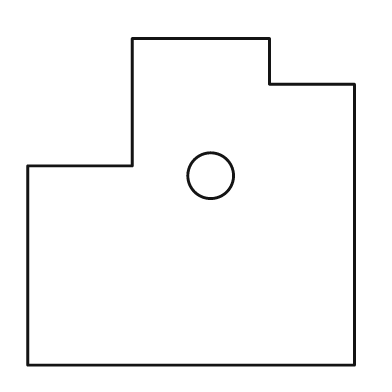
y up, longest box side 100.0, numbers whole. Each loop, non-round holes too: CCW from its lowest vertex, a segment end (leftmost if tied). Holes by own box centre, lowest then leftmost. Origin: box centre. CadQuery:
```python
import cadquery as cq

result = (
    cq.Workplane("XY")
    .moveTo(-50.0, -50.0)
    .lineTo(50.0, -50.0)
    .lineTo(50.0, 36.0)
    .lineTo(24.0, 36.0)
    .lineTo(24.0, 50.0)
    .lineTo(-18.0, 50.0)
    .lineTo(-18.0, 11.0)
    .lineTo(-50.0, 11.0)
    .close()
    .moveTo(6.0, 8.0)
    .circle(7.0)
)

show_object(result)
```